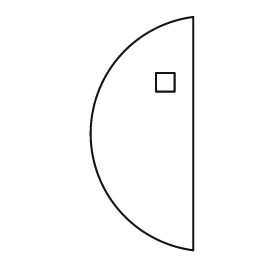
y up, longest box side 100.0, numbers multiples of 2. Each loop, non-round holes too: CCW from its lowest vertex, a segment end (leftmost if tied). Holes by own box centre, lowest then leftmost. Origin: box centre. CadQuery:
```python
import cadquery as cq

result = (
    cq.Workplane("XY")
    .moveTo(22.0, -50.0)
    .lineTo(22.0, 50.0)
    .threePointArc((-22.0, 0.0), (22.0, -50.0))
    .close()
    .moveTo(6.0, 18.0)
    .lineTo(14.0, 18.0)
    .lineTo(14.0, 26.0)
    .lineTo(6.0, 26.0)
    .close()
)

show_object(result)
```